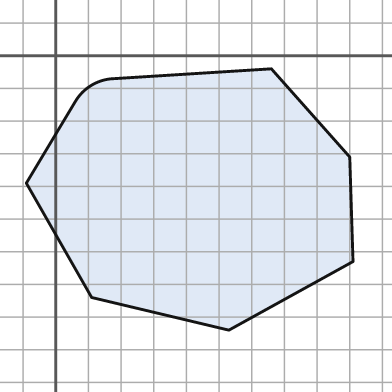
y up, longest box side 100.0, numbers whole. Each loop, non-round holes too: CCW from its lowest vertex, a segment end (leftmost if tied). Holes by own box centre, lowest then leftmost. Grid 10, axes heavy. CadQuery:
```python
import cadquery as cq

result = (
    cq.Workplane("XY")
    .moveTo(53.0, -84.0)
    .lineTo(91.0, -63.0)
    .lineTo(90.0, -31.0)
    .lineTo(66.0, -4.0)
    .lineTo(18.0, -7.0)
    .threePointArc((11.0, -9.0), (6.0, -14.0))
    .lineTo(-9.0, -39.0)
    .lineTo(11.0, -74.0)
    .close()
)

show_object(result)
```